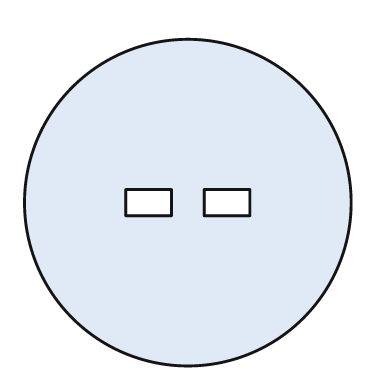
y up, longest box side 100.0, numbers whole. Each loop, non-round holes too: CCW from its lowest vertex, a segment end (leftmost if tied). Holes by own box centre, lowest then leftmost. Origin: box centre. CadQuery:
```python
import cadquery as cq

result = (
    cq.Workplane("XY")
    .moveTo(0.0, 0.0)
    .circle(50.0)
    .moveTo(-19.0, -4.0)
    .lineTo(-5.0, -4.0)
    .lineTo(-5.0, 4.0)
    .lineTo(-19.0, 4.0)
    .close()
    .moveTo(5.0, -4.0)
    .lineTo(19.0, -4.0)
    .lineTo(19.0, 4.0)
    .lineTo(5.0, 4.0)
    .close()
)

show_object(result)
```